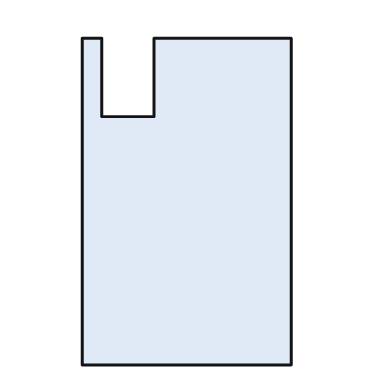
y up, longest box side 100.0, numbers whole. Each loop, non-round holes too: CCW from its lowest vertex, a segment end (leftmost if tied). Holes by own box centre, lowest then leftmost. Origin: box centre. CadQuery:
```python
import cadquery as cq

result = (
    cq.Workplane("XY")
    .moveTo(-32.0, -50.0)
    .lineTo(32.0, -50.0)
    .lineTo(32.0, 50.0)
    .lineTo(-10.0, 50.0)
    .lineTo(-10.0, 26.0)
    .lineTo(-26.0, 26.0)
    .lineTo(-26.0, 50.0)
    .lineTo(-32.0, 50.0)
    .close()
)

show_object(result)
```